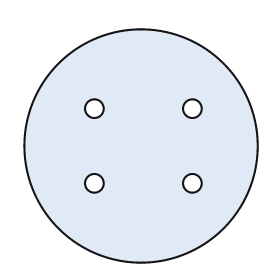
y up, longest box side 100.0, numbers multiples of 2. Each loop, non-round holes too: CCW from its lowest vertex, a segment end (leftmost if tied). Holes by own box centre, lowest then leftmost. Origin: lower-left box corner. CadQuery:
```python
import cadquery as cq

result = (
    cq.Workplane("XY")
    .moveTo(50.0, 50.0)
    .circle(50.0)
    .moveTo(30.0, 34.0)
    .circle(4.0)
    .moveTo(72.0, 34.0)
    .circle(4.0)
    .moveTo(30.0, 66.0)
    .circle(4.0)
    .moveTo(72.0, 66.0)
    .circle(4.0)
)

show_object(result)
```